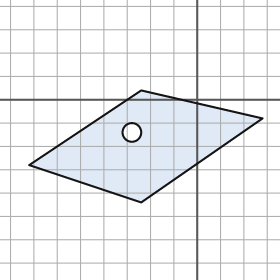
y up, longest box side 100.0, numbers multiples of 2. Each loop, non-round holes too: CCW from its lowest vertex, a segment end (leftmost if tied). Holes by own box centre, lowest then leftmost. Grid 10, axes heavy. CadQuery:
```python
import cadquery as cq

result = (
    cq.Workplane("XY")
    .moveTo(-24.0, -44.0)
    .lineTo(28.0, -8.0)
    .lineTo(-24.0, 4.0)
    .lineTo(-72.0, -28.0)
    .close()
    .moveTo(-28.0, -14.0)
    .circle(4.0)
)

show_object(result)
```